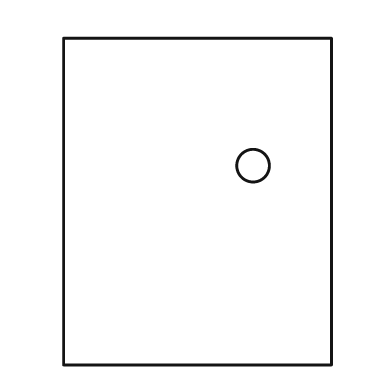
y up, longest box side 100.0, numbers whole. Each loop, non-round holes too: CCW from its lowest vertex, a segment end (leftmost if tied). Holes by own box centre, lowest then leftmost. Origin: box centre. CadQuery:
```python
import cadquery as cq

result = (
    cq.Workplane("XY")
    .moveTo(-41.0, -50.0)
    .lineTo(41.0, -50.0)
    .lineTo(41.0, 50.0)
    .lineTo(-41.0, 50.0)
    .close()
    .moveTo(17.0, 11.0)
    .circle(5.0)
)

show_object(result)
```